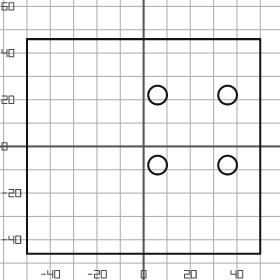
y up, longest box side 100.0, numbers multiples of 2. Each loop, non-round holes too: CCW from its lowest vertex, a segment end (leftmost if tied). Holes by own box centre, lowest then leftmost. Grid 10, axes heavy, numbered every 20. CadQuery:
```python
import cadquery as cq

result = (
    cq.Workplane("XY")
    .moveTo(-50.0, -46.0)
    .lineTo(50.0, -46.0)
    .lineTo(50.0, 46.0)
    .lineTo(-50.0, 46.0)
    .close()
    .moveTo(6.0, -8.0)
    .circle(4.0)
    .moveTo(36.0, -8.0)
    .circle(4.0)
    .moveTo(6.0, 22.0)
    .circle(4.0)
    .moveTo(36.0, 22.0)
    .circle(4.0)
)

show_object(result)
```